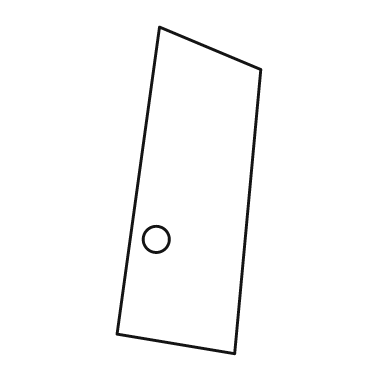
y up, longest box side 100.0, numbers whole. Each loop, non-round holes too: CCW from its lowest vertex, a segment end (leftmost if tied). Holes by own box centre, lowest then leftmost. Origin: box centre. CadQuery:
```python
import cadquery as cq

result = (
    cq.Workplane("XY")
    .moveTo(14.0, -50.0)
    .lineTo(22.0, 37.0)
    .lineTo(-9.0, 50.0)
    .lineTo(-22.0, -44.0)
    .close()
    .moveTo(-10.0, -15.0)
    .circle(4.0)
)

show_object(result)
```